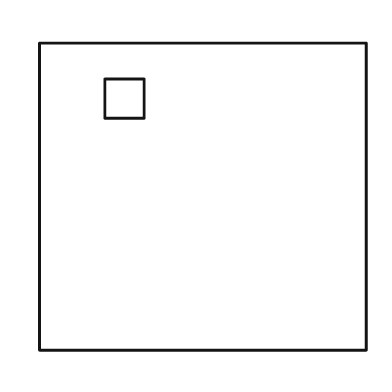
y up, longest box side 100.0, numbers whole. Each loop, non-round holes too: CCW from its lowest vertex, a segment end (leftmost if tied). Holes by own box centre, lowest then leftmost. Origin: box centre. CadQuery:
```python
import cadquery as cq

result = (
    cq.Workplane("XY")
    .moveTo(-50.0, -47.0)
    .lineTo(50.0, -47.0)
    .lineTo(50.0, 47.0)
    .lineTo(-50.0, 47.0)
    .close()
    .moveTo(-30.0, 24.0)
    .lineTo(-18.0, 24.0)
    .lineTo(-18.0, 36.0)
    .lineTo(-30.0, 36.0)
    .close()
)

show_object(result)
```